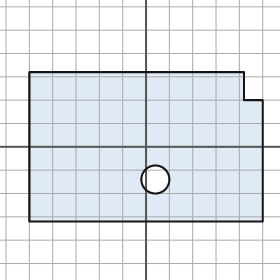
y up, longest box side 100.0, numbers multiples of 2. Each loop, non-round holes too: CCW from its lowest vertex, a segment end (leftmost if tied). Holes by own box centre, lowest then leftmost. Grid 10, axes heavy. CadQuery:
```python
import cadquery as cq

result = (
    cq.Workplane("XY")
    .moveTo(-50.0, -32.0)
    .lineTo(50.0, -32.0)
    .lineTo(50.0, 20.0)
    .lineTo(42.0, 20.0)
    .lineTo(42.0, 32.0)
    .lineTo(-50.0, 32.0)
    .close()
    .moveTo(4.0, -14.0)
    .circle(6.0)
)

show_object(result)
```